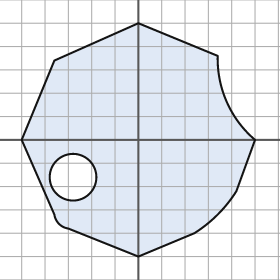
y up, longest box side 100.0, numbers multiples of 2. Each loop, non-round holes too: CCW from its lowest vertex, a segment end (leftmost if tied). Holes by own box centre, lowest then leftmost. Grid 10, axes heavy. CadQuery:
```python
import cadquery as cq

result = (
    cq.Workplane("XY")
    .moveTo(0.0, -50.0)
    .lineTo(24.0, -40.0)
    .threePointArc((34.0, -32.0), (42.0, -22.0))
    .lineTo(50.0, 0.0)
    .threePointArc((38.0, 16.0), (34.0, 36.0))
    .lineTo(0.0, 50.0)
    .lineTo(-36.0, 34.0)
    .lineTo(-50.0, 0.0)
    .lineTo(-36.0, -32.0)
    .threePointArc((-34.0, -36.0), (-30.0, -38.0))
    .close()
    .moveTo(-28.0, -16.0)
    .circle(10.0)
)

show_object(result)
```